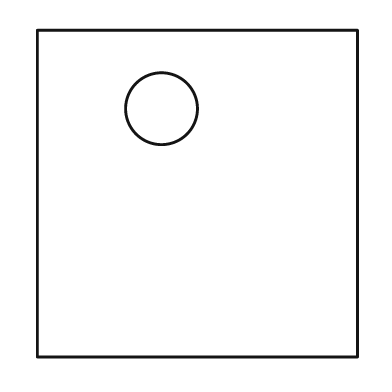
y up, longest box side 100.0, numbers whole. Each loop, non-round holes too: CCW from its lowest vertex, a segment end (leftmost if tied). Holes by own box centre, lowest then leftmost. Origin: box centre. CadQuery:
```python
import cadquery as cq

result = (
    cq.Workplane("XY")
    .moveTo(-49.0, -50.0)
    .lineTo(49.0, -50.0)
    .lineTo(49.0, 50.0)
    .lineTo(-49.0, 50.0)
    .close()
    .moveTo(-11.0, 26.0)
    .circle(11.0)
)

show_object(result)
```